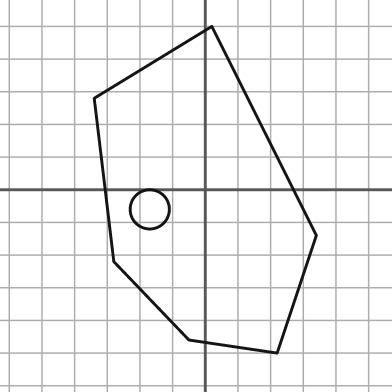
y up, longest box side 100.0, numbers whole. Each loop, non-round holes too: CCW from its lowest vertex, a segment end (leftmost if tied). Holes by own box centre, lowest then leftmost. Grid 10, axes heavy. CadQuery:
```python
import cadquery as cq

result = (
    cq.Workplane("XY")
    .moveTo(22.0, -50.0)
    .lineTo(34.0, -14.0)
    .lineTo(2.0, 50.0)
    .lineTo(-34.0, 28.0)
    .lineTo(-28.0, -22.0)
    .lineTo(-5.0, -46.0)
    .close()
    .moveTo(-17.0, -6.0)
    .circle(6.0)
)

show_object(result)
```